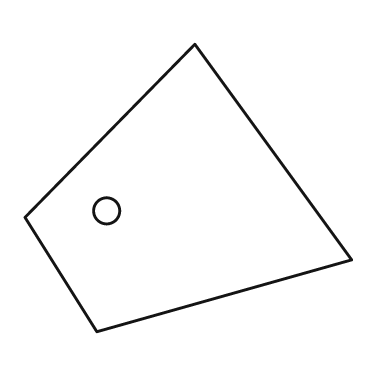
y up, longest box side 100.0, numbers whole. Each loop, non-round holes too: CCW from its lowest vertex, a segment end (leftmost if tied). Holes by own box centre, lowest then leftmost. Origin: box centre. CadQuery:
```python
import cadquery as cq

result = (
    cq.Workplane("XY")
    .moveTo(-28.0, -44.0)
    .lineTo(50.0, -22.0)
    .lineTo(2.0, 44.0)
    .lineTo(-50.0, -9.0)
    .close()
    .moveTo(-25.0, -7.0)
    .circle(4.0)
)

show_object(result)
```